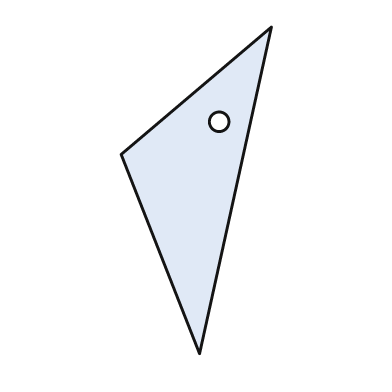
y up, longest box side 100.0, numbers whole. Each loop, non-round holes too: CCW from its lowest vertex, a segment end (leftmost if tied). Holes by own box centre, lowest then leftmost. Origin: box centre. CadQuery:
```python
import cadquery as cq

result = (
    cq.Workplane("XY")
    .moveTo(1.0, -50.0)
    .lineTo(23.0, 50.0)
    .lineTo(-23.0, 11.0)
    .close()
    .moveTo(7.0, 21.0)
    .circle(3.0)
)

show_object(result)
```